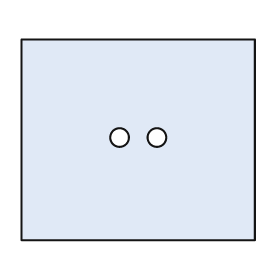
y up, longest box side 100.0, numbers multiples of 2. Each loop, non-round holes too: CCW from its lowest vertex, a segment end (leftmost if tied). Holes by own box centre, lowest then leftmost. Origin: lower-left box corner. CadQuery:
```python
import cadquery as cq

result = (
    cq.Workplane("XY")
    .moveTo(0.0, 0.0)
    .lineTo(100.0, 0.0)
    .lineTo(100.0, 86.0)
    .lineTo(0.0, 86.0)
    .close()
    .moveTo(42.0, 44.0)
    .circle(4.0)
    .moveTo(58.0, 44.0)
    .circle(4.0)
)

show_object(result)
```